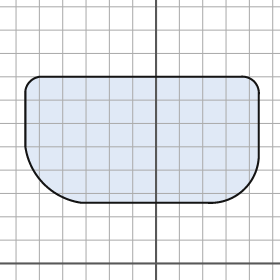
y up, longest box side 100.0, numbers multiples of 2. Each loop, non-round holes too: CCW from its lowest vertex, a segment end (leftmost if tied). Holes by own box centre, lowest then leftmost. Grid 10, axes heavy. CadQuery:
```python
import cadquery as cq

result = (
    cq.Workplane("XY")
    .moveTo(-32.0, 26.0)
    .lineTo(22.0, 26.0)
    .threePointArc((38.0, 32.0), (44.0, 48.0))
    .lineTo(44.0, 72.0)
    .threePointArc((42.0, 78.0), (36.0, 80.0))
    .lineTo(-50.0, 80.0)
    .threePointArc((-54.0, 78.0), (-56.0, 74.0))
    .lineTo(-56.0, 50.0)
    .threePointArc((-48.0, 34.0), (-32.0, 26.0))
    .close()
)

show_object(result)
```